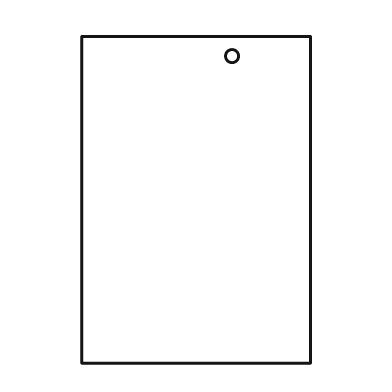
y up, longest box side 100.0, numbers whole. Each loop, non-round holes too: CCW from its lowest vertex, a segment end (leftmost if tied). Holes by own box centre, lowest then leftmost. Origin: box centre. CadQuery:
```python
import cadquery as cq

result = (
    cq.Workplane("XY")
    .moveTo(-35.0, -50.0)
    .lineTo(35.0, -50.0)
    .lineTo(35.0, 50.0)
    .lineTo(-35.0, 50.0)
    .close()
    .moveTo(11.0, 44.0)
    .circle(2.0)
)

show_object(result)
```